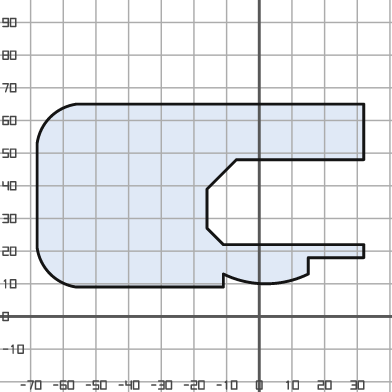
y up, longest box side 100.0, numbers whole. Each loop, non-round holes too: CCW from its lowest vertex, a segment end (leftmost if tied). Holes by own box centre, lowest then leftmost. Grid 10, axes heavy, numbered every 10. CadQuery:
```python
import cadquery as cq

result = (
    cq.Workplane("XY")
    .moveTo(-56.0, 9.0)
    .lineTo(-11.0, 9.0)
    .lineTo(-11.0, 13.0)
    .threePointArc((2.0, 10.0), (15.0, 13.0))
    .lineTo(15.0, 18.0)
    .lineTo(32.0, 18.0)
    .lineTo(32.0, 22.0)
    .lineTo(-11.0, 22.0)
    .lineTo(-16.0, 27.0)
    .lineTo(-16.0, 39.0)
    .lineTo(-7.0, 48.0)
    .lineTo(32.0, 48.0)
    .lineTo(32.0, 65.0)
    .lineTo(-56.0, 65.0)
    .threePointArc((-64.0, 61.0), (-68.0, 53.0))
    .lineTo(-68.0, 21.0)
    .threePointArc((-64.0, 13.0), (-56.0, 9.0))
    .close()
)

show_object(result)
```